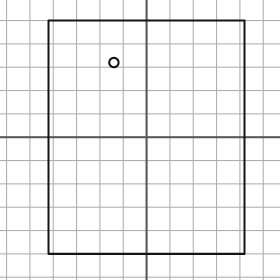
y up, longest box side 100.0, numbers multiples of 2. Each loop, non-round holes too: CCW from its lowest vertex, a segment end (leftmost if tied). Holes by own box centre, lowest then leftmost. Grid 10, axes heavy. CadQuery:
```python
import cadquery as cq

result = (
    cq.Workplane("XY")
    .moveTo(-42.0, -50.0)
    .lineTo(42.0, -50.0)
    .lineTo(42.0, 50.0)
    .lineTo(-42.0, 50.0)
    .close()
    .moveTo(-14.0, 32.0)
    .circle(2.0)
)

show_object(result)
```